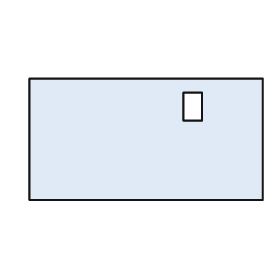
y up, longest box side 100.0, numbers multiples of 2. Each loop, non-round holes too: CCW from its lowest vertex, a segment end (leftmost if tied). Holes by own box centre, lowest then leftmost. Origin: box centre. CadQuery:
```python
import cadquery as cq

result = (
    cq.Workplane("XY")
    .moveTo(-50.0, -26.0)
    .lineTo(50.0, -26.0)
    .lineTo(50.0, 26.0)
    .lineTo(-50.0, 26.0)
    .close()
    .moveTo(16.0, 8.0)
    .lineTo(24.0, 8.0)
    .lineTo(24.0, 20.0)
    .lineTo(16.0, 20.0)
    .close()
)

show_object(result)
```